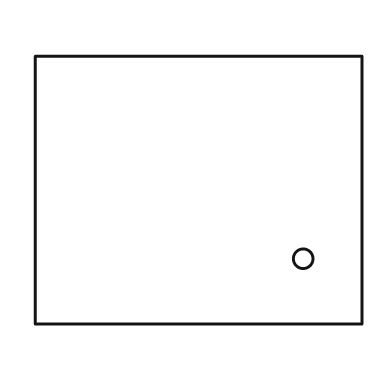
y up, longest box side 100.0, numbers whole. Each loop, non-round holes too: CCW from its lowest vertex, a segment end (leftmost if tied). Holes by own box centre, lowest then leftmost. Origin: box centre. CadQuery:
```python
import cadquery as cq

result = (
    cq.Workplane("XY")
    .moveTo(-50.0, -41.0)
    .lineTo(50.0, -41.0)
    .lineTo(50.0, 41.0)
    .lineTo(-50.0, 41.0)
    .close()
    .moveTo(32.0, -21.0)
    .circle(3.0)
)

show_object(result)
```